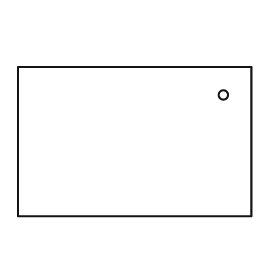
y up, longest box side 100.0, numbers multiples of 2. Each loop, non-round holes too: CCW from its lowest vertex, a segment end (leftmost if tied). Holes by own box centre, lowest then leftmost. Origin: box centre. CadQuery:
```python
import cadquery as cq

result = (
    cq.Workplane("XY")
    .moveTo(-50.0, -32.0)
    .lineTo(50.0, -32.0)
    .lineTo(50.0, 32.0)
    .lineTo(-50.0, 32.0)
    .close()
    .moveTo(38.0, 20.0)
    .circle(2.0)
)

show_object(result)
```